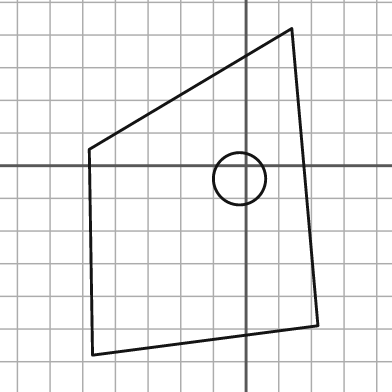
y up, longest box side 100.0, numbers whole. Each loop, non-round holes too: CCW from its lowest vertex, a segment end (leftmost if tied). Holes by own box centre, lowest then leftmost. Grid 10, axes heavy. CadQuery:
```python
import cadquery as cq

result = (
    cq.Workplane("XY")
    .moveTo(-47.0, -58.0)
    .lineTo(22.0, -49.0)
    .lineTo(14.0, 42.0)
    .lineTo(-48.0, 5.0)
    .close()
    .moveTo(-2.0, -4.0)
    .circle(8.0)
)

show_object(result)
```